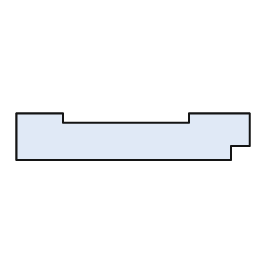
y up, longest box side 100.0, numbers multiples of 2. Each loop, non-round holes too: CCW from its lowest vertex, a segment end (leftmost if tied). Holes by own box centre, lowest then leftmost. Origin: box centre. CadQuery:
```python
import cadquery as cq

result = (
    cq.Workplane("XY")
    .moveTo(-50.0, -10.0)
    .lineTo(42.0, -10.0)
    .lineTo(42.0, -4.0)
    .lineTo(50.0, -4.0)
    .lineTo(50.0, 10.0)
    .lineTo(24.0, 10.0)
    .lineTo(24.0, 6.0)
    .lineTo(-30.0, 6.0)
    .lineTo(-30.0, 10.0)
    .lineTo(-50.0, 10.0)
    .close()
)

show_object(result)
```